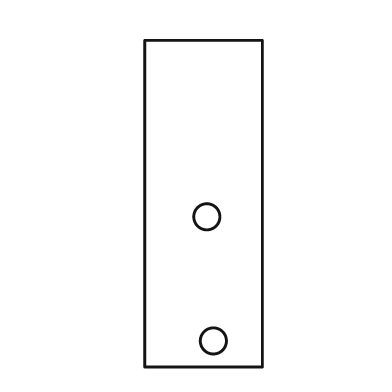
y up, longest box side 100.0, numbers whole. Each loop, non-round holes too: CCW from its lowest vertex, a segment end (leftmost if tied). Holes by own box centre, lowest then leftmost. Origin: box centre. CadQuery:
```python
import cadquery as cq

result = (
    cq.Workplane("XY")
    .moveTo(-18.0, -50.0)
    .lineTo(18.0, -50.0)
    .lineTo(18.0, 50.0)
    .lineTo(-18.0, 50.0)
    .close()
    .moveTo(3.0, -42.0)
    .circle(4.0)
    .moveTo(1.0, -4.0)
    .circle(4.0)
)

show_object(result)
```